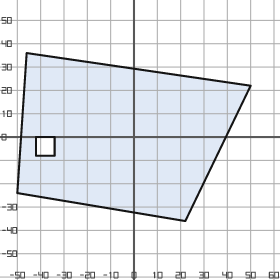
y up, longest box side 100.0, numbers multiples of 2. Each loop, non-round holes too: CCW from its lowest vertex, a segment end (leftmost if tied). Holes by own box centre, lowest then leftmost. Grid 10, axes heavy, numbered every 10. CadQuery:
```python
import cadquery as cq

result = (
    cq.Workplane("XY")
    .moveTo(22.0, -36.0)
    .lineTo(50.0, 22.0)
    .lineTo(-46.0, 36.0)
    .lineTo(-50.0, -24.0)
    .close()
    .moveTo(-42.0, -8.0)
    .lineTo(-34.0, -8.0)
    .lineTo(-34.0, 0.0)
    .lineTo(-42.0, 0.0)
    .close()
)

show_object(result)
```